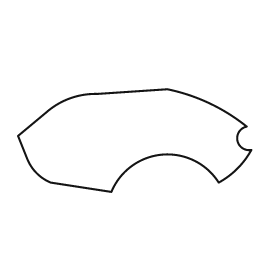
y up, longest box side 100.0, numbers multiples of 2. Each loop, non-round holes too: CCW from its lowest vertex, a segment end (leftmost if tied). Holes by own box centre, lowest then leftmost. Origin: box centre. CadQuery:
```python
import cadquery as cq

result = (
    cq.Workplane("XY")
    .moveTo(-10.0, -22.0)
    .threePointArc((12.0, -6.0), (36.0, -18.0))
    .threePointArc((44.0, -12.0), (50.0, -4.0))
    .threePointArc((44.0, 0.0), (48.0, 6.0))
    .threePointArc((32.0, 16.0), (14.0, 22.0))
    .lineTo(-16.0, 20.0)
    .threePointArc((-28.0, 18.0), (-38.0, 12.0))
    .lineTo(-50.0, 2.0)
    .lineTo(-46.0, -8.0)
    .threePointArc((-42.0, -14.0), (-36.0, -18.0))
    .close()
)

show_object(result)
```